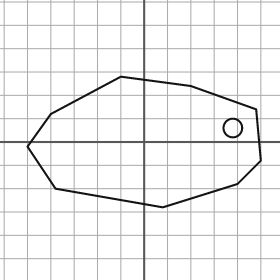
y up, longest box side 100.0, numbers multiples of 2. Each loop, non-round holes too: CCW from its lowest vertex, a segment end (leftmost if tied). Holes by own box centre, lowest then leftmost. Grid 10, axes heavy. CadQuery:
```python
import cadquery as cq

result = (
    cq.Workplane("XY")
    .moveTo(8.0, -28.0)
    .lineTo(40.0, -18.0)
    .lineTo(50.0, -8.0)
    .lineTo(48.0, 14.0)
    .lineTo(20.0, 24.0)
    .lineTo(-10.0, 28.0)
    .lineTo(-40.0, 12.0)
    .lineTo(-50.0, -2.0)
    .lineTo(-38.0, -20.0)
    .close()
    .moveTo(38.0, 6.0)
    .circle(4.0)
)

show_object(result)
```